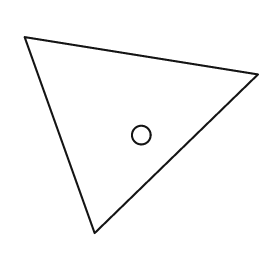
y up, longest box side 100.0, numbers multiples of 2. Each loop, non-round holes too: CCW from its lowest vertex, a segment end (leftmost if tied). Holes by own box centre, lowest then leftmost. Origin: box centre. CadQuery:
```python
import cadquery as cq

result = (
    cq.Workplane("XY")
    .moveTo(-20.0, -42.0)
    .lineTo(50.0, 26.0)
    .lineTo(-50.0, 42.0)
    .close()
    .moveTo(0.0, 0.0)
    .circle(4.0)
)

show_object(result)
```